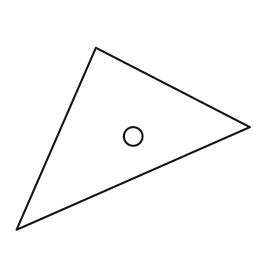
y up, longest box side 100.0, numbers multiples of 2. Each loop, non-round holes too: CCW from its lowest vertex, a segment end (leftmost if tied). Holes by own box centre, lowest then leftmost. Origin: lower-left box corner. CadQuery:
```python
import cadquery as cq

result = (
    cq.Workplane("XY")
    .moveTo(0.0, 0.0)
    .lineTo(100.0, 44.0)
    .lineTo(34.0, 78.0)
    .close()
    .moveTo(50.0, 40.0)
    .circle(4.0)
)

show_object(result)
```